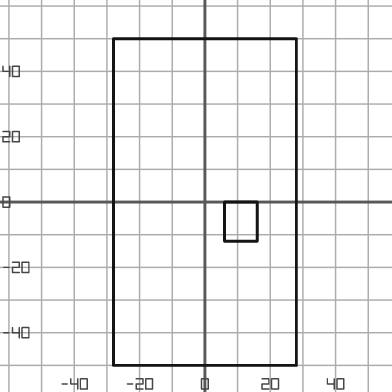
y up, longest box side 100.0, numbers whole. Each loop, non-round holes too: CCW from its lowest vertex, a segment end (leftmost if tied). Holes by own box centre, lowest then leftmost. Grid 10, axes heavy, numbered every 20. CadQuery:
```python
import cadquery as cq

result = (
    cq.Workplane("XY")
    .moveTo(-28.0, -50.0)
    .lineTo(28.0, -50.0)
    .lineTo(28.0, 50.0)
    .lineTo(-28.0, 50.0)
    .close()
    .moveTo(6.0, -12.0)
    .lineTo(16.0, -12.0)
    .lineTo(16.0, 0.0)
    .lineTo(6.0, 0.0)
    .close()
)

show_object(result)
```